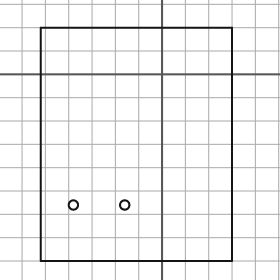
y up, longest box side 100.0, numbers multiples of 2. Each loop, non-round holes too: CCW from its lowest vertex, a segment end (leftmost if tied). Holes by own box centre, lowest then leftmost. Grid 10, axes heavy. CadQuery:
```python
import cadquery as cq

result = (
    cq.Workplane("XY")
    .moveTo(-52.0, -80.0)
    .lineTo(30.0, -80.0)
    .lineTo(30.0, 20.0)
    .lineTo(-52.0, 20.0)
    .close()
    .moveTo(-38.0, -56.0)
    .circle(2.0)
    .moveTo(-16.0, -56.0)
    .circle(2.0)
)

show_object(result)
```